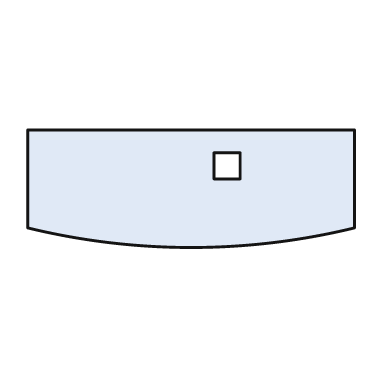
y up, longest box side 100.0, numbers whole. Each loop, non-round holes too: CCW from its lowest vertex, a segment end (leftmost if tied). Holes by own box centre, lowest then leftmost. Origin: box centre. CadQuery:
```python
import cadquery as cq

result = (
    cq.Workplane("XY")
    .moveTo(-50.0, -12.0)
    .threePointArc((0.0, -18.0), (50.0, -12.0))
    .lineTo(50.0, 18.0)
    .lineTo(-50.0, 18.0)
    .close()
    .moveTo(7.0, 3.0)
    .lineTo(15.0, 3.0)
    .lineTo(15.0, 11.0)
    .lineTo(7.0, 11.0)
    .close()
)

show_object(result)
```